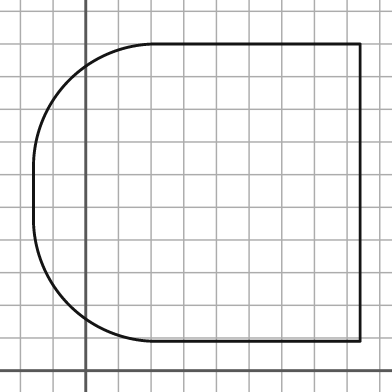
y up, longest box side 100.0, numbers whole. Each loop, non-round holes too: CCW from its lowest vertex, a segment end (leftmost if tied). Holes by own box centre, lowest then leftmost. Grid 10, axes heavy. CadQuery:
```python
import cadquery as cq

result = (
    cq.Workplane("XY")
    .moveTo(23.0, 9.0)
    .lineTo(84.0, 9.0)
    .lineTo(84.0, 100.0)
    .lineTo(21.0, 100.0)
    .threePointArc((-5.0, 89.0), (-16.0, 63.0))
    .lineTo(-16.0, 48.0)
    .threePointArc((-5.0, 20.0), (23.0, 9.0))
    .close()
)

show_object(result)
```